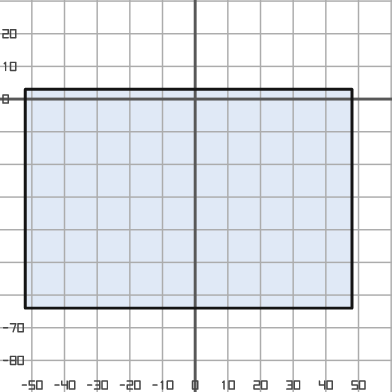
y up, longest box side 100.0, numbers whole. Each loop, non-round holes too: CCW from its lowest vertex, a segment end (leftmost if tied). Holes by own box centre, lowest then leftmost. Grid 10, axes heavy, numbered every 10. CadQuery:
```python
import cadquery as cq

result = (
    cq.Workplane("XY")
    .moveTo(-52.0, -64.0)
    .lineTo(48.0, -64.0)
    .lineTo(48.0, 3.0)
    .lineTo(-52.0, 3.0)
    .close()
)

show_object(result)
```